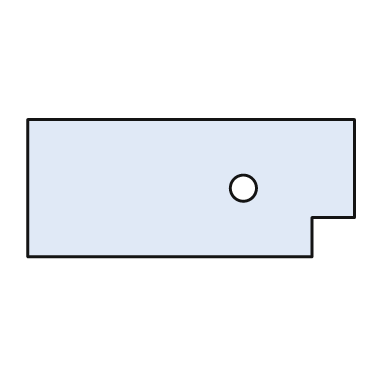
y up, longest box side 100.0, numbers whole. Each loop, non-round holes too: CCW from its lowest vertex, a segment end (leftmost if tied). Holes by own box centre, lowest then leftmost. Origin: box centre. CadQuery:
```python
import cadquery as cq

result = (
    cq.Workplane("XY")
    .moveTo(-50.0, -21.0)
    .lineTo(37.0, -21.0)
    .lineTo(37.0, -9.0)
    .lineTo(50.0, -9.0)
    .lineTo(50.0, 21.0)
    .lineTo(-50.0, 21.0)
    .close()
    .moveTo(16.0, 0.0)
    .circle(4.0)
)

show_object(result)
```